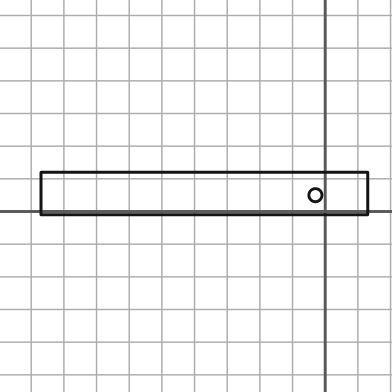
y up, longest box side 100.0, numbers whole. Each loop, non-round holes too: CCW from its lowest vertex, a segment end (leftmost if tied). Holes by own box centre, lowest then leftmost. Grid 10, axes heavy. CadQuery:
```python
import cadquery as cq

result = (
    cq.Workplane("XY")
    .moveTo(-87.0, -1.0)
    .lineTo(13.0, -1.0)
    .lineTo(13.0, 12.0)
    .lineTo(-87.0, 12.0)
    .close()
    .moveTo(-3.0, 5.0)
    .circle(2.0)
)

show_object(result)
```